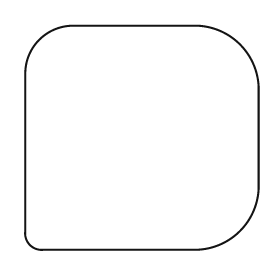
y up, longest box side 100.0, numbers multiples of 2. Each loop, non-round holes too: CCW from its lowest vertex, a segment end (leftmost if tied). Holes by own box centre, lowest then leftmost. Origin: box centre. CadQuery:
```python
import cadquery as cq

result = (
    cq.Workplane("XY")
    .moveTo(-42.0, -48.0)
    .lineTo(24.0, -48.0)
    .threePointArc((42.0, -40.0), (50.0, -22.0))
    .lineTo(50.0, 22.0)
    .threePointArc((42.0, 40.0), (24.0, 48.0))
    .lineTo(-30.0, 48.0)
    .threePointArc((-44.0, 42.0), (-50.0, 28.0))
    .lineTo(-50.0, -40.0)
    .threePointArc((-48.0, -46.0), (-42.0, -48.0))
    .close()
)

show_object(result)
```